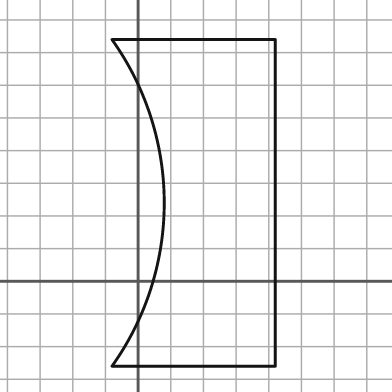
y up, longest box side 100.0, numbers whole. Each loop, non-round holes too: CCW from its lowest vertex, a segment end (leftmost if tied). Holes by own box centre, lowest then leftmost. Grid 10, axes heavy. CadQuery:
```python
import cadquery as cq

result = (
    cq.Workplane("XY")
    .moveTo(-8.0, -26.0)
    .lineTo(42.0, -26.0)
    .lineTo(42.0, 74.0)
    .lineTo(-8.0, 74.0)
    .threePointArc((8.0, 24.0), (-8.0, -26.0))
    .close()
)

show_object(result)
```